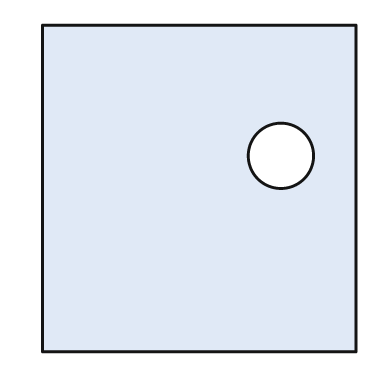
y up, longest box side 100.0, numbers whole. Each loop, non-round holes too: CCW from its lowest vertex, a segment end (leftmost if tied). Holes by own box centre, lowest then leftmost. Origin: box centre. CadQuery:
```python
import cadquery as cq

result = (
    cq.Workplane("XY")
    .moveTo(-48.0, -50.0)
    .lineTo(48.0, -50.0)
    .lineTo(48.0, 50.0)
    .lineTo(-48.0, 50.0)
    .close()
    .moveTo(25.0, 10.0)
    .circle(10.0)
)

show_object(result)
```